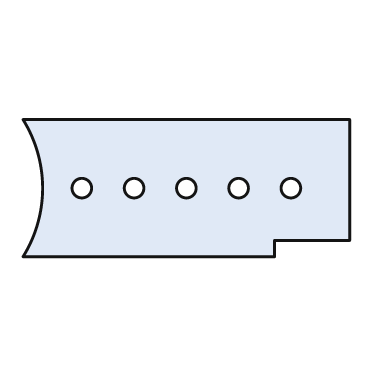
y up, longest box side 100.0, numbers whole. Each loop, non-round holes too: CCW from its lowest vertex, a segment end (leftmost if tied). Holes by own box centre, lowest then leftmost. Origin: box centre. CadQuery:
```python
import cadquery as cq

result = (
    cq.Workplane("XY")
    .moveTo(-50.0, -21.0)
    .lineTo(27.0, -21.0)
    .lineTo(27.0, -16.0)
    .lineTo(50.0, -16.0)
    .lineTo(50.0, 21.0)
    .lineTo(-50.0, 21.0)
    .threePointArc((-44.0, 0.0), (-50.0, -21.0))
    .close()
    .moveTo(-32.0, 0.0)
    .circle(3.0)
    .moveTo(-16.0, 0.0)
    .circle(3.0)
    .moveTo(0.0, 0.0)
    .circle(3.0)
    .moveTo(16.0, 0.0)
    .circle(3.0)
    .moveTo(32.0, 0.0)
    .circle(3.0)
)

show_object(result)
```